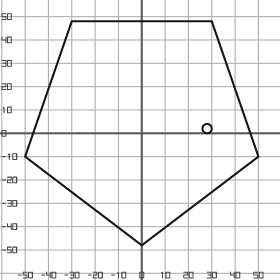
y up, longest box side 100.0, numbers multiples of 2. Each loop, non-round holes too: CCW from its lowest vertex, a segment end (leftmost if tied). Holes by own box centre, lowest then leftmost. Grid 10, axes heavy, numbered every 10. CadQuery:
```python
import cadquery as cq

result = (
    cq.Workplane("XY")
    .moveTo(0.0, -48.0)
    .lineTo(50.0, -10.0)
    .lineTo(30.0, 48.0)
    .lineTo(-30.0, 48.0)
    .lineTo(-50.0, -10.0)
    .close()
    .moveTo(28.0, 2.0)
    .circle(2.0)
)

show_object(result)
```